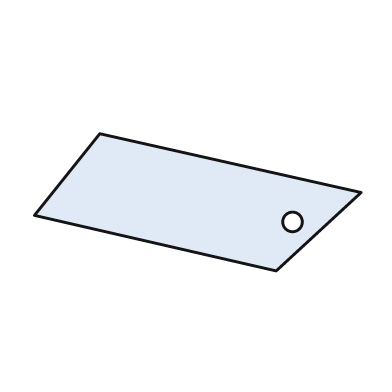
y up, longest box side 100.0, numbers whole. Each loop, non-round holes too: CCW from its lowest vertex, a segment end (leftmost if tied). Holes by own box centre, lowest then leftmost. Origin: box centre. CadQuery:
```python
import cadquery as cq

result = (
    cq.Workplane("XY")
    .moveTo(24.0, -21.0)
    .lineTo(50.0, 3.0)
    .lineTo(-30.0, 21.0)
    .lineTo(-50.0, -4.0)
    .close()
    .moveTo(29.0, -6.0)
    .circle(3.0)
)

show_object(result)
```